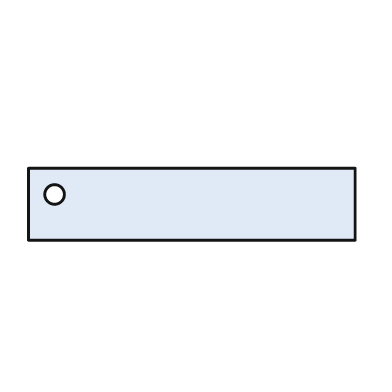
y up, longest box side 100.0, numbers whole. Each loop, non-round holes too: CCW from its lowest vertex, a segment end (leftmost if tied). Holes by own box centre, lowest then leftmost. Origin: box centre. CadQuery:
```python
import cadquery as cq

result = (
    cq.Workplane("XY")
    .moveTo(-50.0, -11.0)
    .lineTo(50.0, -11.0)
    .lineTo(50.0, 11.0)
    .lineTo(-50.0, 11.0)
    .close()
    .moveTo(-42.0, 3.0)
    .circle(3.0)
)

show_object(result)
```